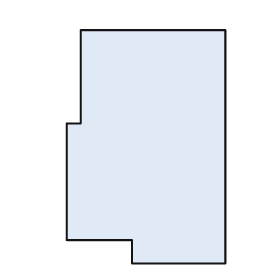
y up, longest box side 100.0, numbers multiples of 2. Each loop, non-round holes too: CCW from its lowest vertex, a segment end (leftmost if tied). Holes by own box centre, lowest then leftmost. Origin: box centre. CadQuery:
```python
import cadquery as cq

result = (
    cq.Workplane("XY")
    .moveTo(-6.0, -50.0)
    .lineTo(34.0, -50.0)
    .lineTo(34.0, 50.0)
    .lineTo(-28.0, 50.0)
    .lineTo(-28.0, 10.0)
    .lineTo(-34.0, 10.0)
    .lineTo(-34.0, -40.0)
    .lineTo(-6.0, -40.0)
    .close()
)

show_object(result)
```